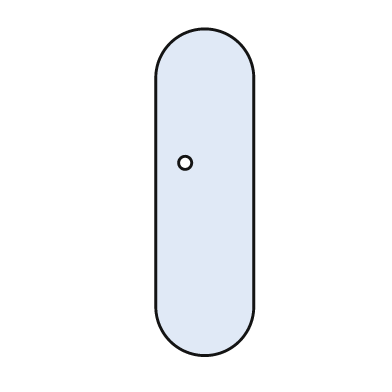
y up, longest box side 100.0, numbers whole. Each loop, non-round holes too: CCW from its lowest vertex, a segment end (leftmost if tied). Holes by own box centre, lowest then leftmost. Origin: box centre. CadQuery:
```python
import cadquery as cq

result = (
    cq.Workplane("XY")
    .moveTo(-15.0, -35.0)
    .threePointArc((0.0, -50.0), (15.0, -35.0))
    .lineTo(15.0, 35.0)
    .threePointArc((0.0, 50.0), (-15.0, 35.0))
    .close()
    .moveTo(-6.0, 9.0)
    .circle(2.0)
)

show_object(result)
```